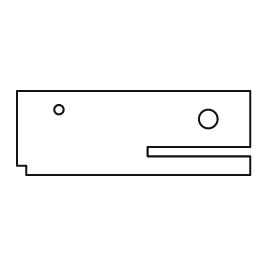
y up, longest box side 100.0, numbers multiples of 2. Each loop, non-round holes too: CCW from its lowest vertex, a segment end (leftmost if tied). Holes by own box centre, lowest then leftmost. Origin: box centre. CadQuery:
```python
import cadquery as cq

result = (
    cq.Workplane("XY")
    .moveTo(-46.0, -18.0)
    .lineTo(50.0, -18.0)
    .lineTo(50.0, -10.0)
    .lineTo(6.0, -10.0)
    .lineTo(6.0, -6.0)
    .lineTo(50.0, -6.0)
    .lineTo(50.0, 18.0)
    .lineTo(-50.0, 18.0)
    .lineTo(-50.0, -14.0)
    .lineTo(-46.0, -14.0)
    .close()
    .moveTo(32.0, 6.0)
    .circle(4.0)
    .moveTo(-32.0, 10.0)
    .circle(2.0)
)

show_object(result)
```